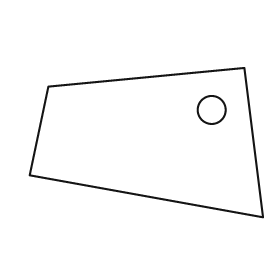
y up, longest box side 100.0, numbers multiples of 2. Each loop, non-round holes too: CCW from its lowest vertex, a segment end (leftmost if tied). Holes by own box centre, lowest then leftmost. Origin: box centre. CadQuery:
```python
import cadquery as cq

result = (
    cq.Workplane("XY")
    .moveTo(50.0, -32.0)
    .lineTo(42.0, 32.0)
    .lineTo(-42.0, 24.0)
    .lineTo(-50.0, -14.0)
    .close()
    .moveTo(28.0, 14.0)
    .circle(6.0)
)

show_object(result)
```